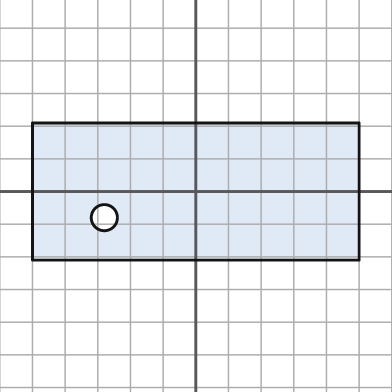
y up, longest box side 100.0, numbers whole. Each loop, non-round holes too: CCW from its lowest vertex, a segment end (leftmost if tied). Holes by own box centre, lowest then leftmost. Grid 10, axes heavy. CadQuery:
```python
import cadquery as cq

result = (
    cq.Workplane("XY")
    .moveTo(-50.0, -21.0)
    .lineTo(50.0, -21.0)
    .lineTo(50.0, 21.0)
    .lineTo(-50.0, 21.0)
    .close()
    .moveTo(-28.0, -8.0)
    .circle(4.0)
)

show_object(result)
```